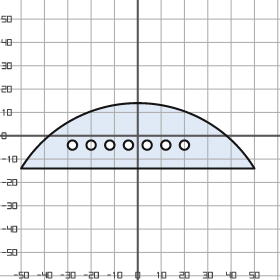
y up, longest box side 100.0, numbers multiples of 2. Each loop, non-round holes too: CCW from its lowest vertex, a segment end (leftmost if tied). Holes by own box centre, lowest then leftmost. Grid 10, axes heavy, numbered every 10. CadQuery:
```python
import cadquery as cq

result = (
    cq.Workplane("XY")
    .moveTo(-50.0, -14.0)
    .lineTo(50.0, -14.0)
    .threePointArc((0.0, 14.0), (-50.0, -14.0))
    .close()
    .moveTo(-28.0, -4.0)
    .circle(2.0)
    .moveTo(-20.0, -4.0)
    .circle(2.0)
    .moveTo(-12.0, -4.0)
    .circle(2.0)
    .moveTo(-4.0, -4.0)
    .circle(2.0)
    .moveTo(4.0, -4.0)
    .circle(2.0)
    .moveTo(12.0, -4.0)
    .circle(2.0)
    .moveTo(20.0, -4.0)
    .circle(2.0)
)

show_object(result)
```